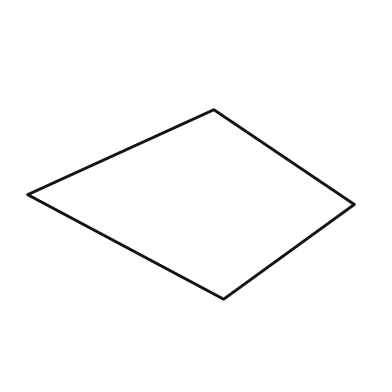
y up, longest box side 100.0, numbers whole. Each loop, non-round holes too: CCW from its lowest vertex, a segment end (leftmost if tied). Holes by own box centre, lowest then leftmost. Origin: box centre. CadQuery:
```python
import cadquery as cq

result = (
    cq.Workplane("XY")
    .moveTo(10.0, -29.0)
    .lineTo(50.0, 0.0)
    .lineTo(7.0, 29.0)
    .lineTo(-50.0, 3.0)
    .close()
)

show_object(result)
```